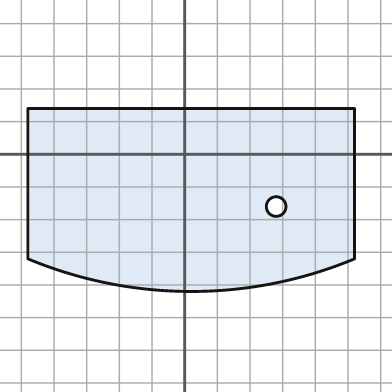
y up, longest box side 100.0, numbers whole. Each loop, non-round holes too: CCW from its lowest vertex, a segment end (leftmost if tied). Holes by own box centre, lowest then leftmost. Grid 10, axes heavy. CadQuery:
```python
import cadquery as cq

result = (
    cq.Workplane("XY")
    .moveTo(-48.0, -32.0)
    .threePointArc((2.0, -42.0), (52.0, -32.0))
    .lineTo(52.0, 14.0)
    .lineTo(-48.0, 14.0)
    .close()
    .moveTo(28.0, -16.0)
    .circle(3.0)
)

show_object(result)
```